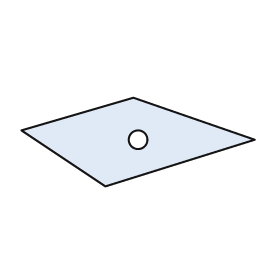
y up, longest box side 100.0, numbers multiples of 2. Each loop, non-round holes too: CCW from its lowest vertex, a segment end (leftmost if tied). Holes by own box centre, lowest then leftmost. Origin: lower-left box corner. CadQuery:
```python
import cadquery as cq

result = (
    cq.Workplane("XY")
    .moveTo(36.0, 0.0)
    .lineTo(100.0, 20.0)
    .lineTo(48.0, 38.0)
    .lineTo(0.0, 24.0)
    .close()
    .moveTo(50.0, 20.0)
    .circle(4.0)
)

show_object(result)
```